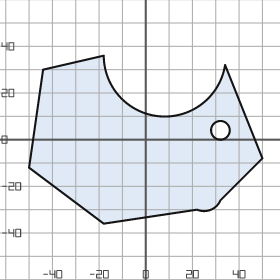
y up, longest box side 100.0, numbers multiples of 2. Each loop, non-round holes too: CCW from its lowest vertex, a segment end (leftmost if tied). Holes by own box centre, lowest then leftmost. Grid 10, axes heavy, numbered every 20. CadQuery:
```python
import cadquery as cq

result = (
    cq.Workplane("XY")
    .moveTo(-18.0, -36.0)
    .lineTo(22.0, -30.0)
    .threePointArc((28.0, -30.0), (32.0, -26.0))
    .lineTo(50.0, -8.0)
    .lineTo(34.0, 32.0)
    .threePointArc((6.0, 10.0), (-18.0, 36.0))
    .lineTo(-44.0, 30.0)
    .lineTo(-50.0, -12.0)
    .close()
    .moveTo(32.0, 4.0)
    .circle(4.0)
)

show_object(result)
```